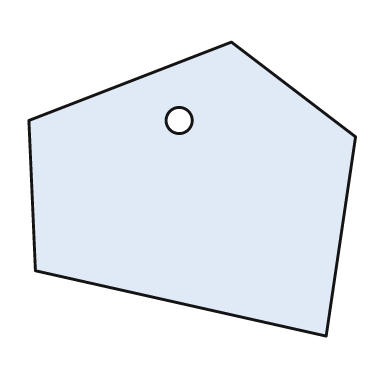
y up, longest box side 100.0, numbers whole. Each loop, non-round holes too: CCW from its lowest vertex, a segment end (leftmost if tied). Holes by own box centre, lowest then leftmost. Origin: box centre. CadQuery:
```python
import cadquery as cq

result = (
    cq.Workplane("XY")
    .moveTo(41.0, -45.0)
    .lineTo(50.0, 16.0)
    .lineTo(12.0, 45.0)
    .lineTo(-50.0, 21.0)
    .lineTo(-48.0, -25.0)
    .close()
    .moveTo(-4.0, 21.0)
    .circle(4.0)
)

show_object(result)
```